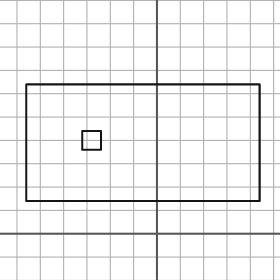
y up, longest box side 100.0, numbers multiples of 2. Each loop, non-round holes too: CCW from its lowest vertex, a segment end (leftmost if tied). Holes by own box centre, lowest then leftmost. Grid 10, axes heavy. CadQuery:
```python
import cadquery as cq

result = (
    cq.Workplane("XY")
    .moveTo(-56.0, 14.0)
    .lineTo(44.0, 14.0)
    .lineTo(44.0, 64.0)
    .lineTo(-56.0, 64.0)
    .close()
    .moveTo(-32.0, 36.0)
    .lineTo(-24.0, 36.0)
    .lineTo(-24.0, 44.0)
    .lineTo(-32.0, 44.0)
    .close()
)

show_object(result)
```